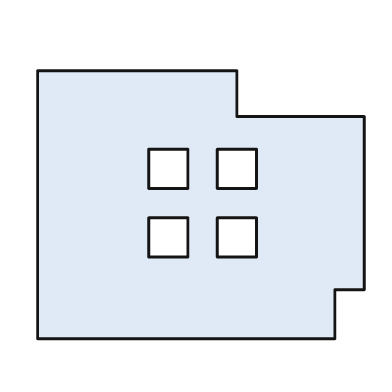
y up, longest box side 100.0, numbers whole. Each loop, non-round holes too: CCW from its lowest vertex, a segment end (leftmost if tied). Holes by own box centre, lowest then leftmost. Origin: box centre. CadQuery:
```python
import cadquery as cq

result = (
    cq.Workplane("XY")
    .moveTo(-50.0, -41.0)
    .lineTo(41.0, -41.0)
    .lineTo(41.0, -26.0)
    .lineTo(50.0, -26.0)
    .lineTo(50.0, 27.0)
    .lineTo(11.0, 27.0)
    .lineTo(11.0, 41.0)
    .lineTo(-50.0, 41.0)
    .close()
    .moveTo(-16.0, -16.0)
    .lineTo(-4.0, -16.0)
    .lineTo(-4.0, -4.0)
    .lineTo(-16.0, -4.0)
    .close()
    .moveTo(5.0, -16.0)
    .lineTo(17.0, -16.0)
    .lineTo(17.0, -4.0)
    .lineTo(5.0, -4.0)
    .close()
    .moveTo(-16.0, 5.0)
    .lineTo(-4.0, 5.0)
    .lineTo(-4.0, 17.0)
    .lineTo(-16.0, 17.0)
    .close()
    .moveTo(5.0, 5.0)
    .lineTo(17.0, 5.0)
    .lineTo(17.0, 17.0)
    .lineTo(5.0, 17.0)
    .close()
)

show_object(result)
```